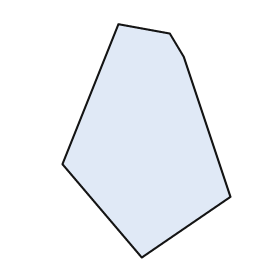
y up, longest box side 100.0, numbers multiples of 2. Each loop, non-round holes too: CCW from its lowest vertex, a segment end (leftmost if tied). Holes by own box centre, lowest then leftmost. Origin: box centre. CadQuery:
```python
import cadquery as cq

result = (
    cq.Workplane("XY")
    .moveTo(-2.0, -50.0)
    .lineTo(36.0, -24.0)
    .lineTo(16.0, 36.0)
    .lineTo(10.0, 46.0)
    .lineTo(-12.0, 50.0)
    .lineTo(-36.0, -10.0)
    .close()
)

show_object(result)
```